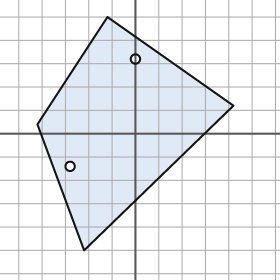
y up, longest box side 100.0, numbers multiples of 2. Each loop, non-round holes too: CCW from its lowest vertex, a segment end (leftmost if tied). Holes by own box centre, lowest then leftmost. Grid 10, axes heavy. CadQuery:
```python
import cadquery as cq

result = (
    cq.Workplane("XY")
    .moveTo(-22.0, -50.0)
    .lineTo(42.0, 12.0)
    .lineTo(-12.0, 50.0)
    .lineTo(-42.0, 4.0)
    .close()
    .moveTo(-28.0, -14.0)
    .circle(2.0)
    .moveTo(0.0, 32.0)
    .circle(2.0)
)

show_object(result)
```